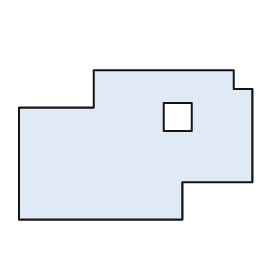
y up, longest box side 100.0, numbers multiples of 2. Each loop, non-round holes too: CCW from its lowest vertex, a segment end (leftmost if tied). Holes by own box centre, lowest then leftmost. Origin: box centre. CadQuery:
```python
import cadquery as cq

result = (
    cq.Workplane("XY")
    .moveTo(-50.0, -32.0)
    .lineTo(20.0, -32.0)
    .lineTo(20.0, -16.0)
    .lineTo(50.0, -16.0)
    .lineTo(50.0, 24.0)
    .lineTo(42.0, 24.0)
    .lineTo(42.0, 32.0)
    .lineTo(-18.0, 32.0)
    .lineTo(-18.0, 16.0)
    .lineTo(-50.0, 16.0)
    .close()
    .moveTo(12.0, 6.0)
    .lineTo(24.0, 6.0)
    .lineTo(24.0, 18.0)
    .lineTo(12.0, 18.0)
    .close()
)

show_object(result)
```